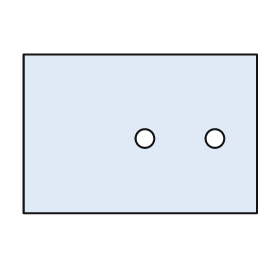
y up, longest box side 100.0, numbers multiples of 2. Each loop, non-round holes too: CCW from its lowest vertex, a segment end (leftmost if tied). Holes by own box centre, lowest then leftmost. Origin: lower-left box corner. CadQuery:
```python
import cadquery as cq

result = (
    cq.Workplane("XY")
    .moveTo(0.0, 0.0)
    .lineTo(100.0, 0.0)
    .lineTo(100.0, 68.0)
    .lineTo(0.0, 68.0)
    .close()
    .moveTo(52.0, 32.0)
    .circle(4.0)
    .moveTo(82.0, 32.0)
    .circle(4.0)
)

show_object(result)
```